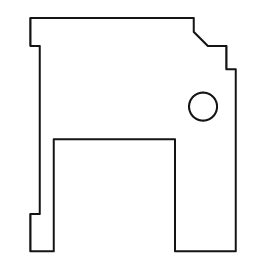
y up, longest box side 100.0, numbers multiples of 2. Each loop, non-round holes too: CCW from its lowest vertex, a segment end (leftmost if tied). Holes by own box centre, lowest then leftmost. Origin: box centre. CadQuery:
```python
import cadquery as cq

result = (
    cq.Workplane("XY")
    .moveTo(-44.0, -50.0)
    .lineTo(-34.0, -50.0)
    .lineTo(-34.0, -2.0)
    .lineTo(18.0, -2.0)
    .lineTo(18.0, -50.0)
    .lineTo(44.0, -50.0)
    .lineTo(44.0, 28.0)
    .lineTo(40.0, 28.0)
    .lineTo(40.0, 38.0)
    .lineTo(32.0, 38.0)
    .lineTo(26.0, 44.0)
    .lineTo(26.0, 50.0)
    .lineTo(-44.0, 50.0)
    .lineTo(-44.0, 38.0)
    .lineTo(-40.0, 38.0)
    .lineTo(-40.0, -34.0)
    .lineTo(-44.0, -34.0)
    .close()
    .moveTo(30.0, 12.0)
    .circle(6.0)
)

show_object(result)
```